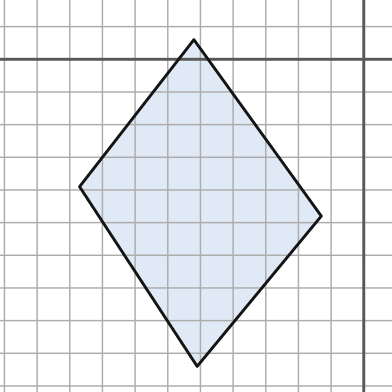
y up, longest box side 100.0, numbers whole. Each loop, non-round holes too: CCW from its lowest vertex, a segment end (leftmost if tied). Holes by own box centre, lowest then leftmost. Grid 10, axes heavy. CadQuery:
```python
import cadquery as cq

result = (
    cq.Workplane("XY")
    .moveTo(-51.0, -94.0)
    .lineTo(-13.0, -48.0)
    .lineTo(-52.0, 6.0)
    .lineTo(-87.0, -39.0)
    .close()
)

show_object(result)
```